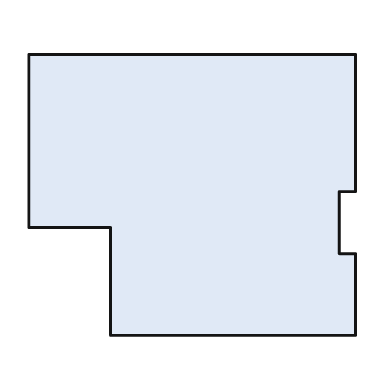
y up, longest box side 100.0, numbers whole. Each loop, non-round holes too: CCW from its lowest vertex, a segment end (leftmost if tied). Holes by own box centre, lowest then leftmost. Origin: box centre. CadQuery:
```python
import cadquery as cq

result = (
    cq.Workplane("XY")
    .moveTo(-25.0, -43.0)
    .lineTo(50.0, -43.0)
    .lineTo(50.0, -18.0)
    .lineTo(45.0, -18.0)
    .lineTo(45.0, 1.0)
    .lineTo(50.0, 1.0)
    .lineTo(50.0, 43.0)
    .lineTo(-50.0, 43.0)
    .lineTo(-50.0, -10.0)
    .lineTo(-25.0, -10.0)
    .close()
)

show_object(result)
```